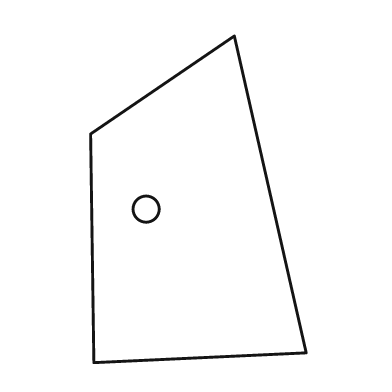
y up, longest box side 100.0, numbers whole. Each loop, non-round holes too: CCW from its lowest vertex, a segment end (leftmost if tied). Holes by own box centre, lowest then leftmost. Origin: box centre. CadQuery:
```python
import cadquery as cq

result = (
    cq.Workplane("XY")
    .moveTo(-32.0, -50.0)
    .lineTo(33.0, -47.0)
    .lineTo(11.0, 50.0)
    .lineTo(-33.0, 20.0)
    .close()
    .moveTo(-16.0, -3.0)
    .circle(4.0)
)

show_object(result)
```